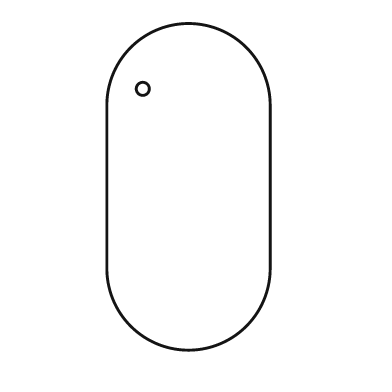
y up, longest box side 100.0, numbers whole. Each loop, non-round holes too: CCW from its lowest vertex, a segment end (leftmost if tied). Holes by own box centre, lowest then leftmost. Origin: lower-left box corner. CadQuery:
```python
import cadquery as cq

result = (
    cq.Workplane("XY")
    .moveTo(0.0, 25.0)
    .threePointArc((25.0, 0.0), (50.0, 25.0))
    .lineTo(50.0, 75.0)
    .threePointArc((25.0, 100.0), (0.0, 75.0))
    .close()
    .moveTo(11.0, 80.0)
    .circle(2.0)
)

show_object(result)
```